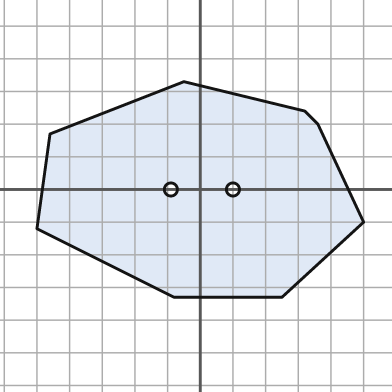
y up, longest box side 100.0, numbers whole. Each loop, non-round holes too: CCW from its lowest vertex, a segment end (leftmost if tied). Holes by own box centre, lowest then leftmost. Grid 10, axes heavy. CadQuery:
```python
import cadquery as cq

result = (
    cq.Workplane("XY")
    .moveTo(-8.0, -33.0)
    .lineTo(25.0, -33.0)
    .lineTo(50.0, -10.0)
    .lineTo(36.0, 20.0)
    .lineTo(32.0, 24.0)
    .lineTo(-5.0, 33.0)
    .lineTo(-46.0, 17.0)
    .lineTo(-50.0, -12.0)
    .close()
    .moveTo(-9.0, 0.0)
    .circle(2.0)
    .moveTo(10.0, 0.0)
    .circle(2.0)
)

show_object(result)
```